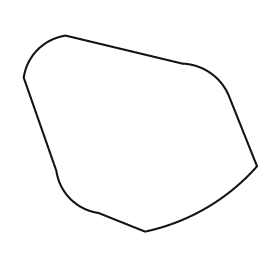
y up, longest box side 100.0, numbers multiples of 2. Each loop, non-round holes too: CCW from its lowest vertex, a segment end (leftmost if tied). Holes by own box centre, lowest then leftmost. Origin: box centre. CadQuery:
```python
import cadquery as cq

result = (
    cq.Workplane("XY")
    .moveTo(2.0, -42.0)
    .threePointArc((28.0, -32.0), (50.0, -14.0))
    .lineTo(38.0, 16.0)
    .threePointArc((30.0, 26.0), (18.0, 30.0))
    .lineTo(-32.0, 42.0)
    .threePointArc((-44.0, 36.0), (-50.0, 24.0))
    .lineTo(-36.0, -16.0)
    .threePointArc((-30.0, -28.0), (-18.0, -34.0))
    .close()
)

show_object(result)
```